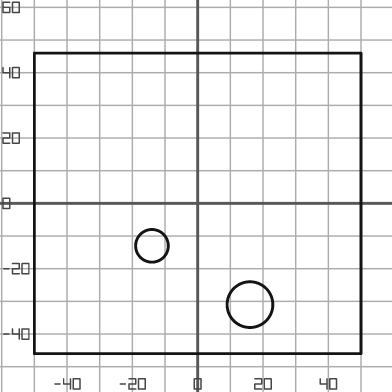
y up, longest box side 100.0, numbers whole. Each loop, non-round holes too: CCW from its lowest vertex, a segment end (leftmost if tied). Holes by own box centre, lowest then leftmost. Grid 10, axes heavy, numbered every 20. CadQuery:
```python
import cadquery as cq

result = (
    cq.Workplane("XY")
    .moveTo(-50.0, -46.0)
    .lineTo(50.0, -46.0)
    .lineTo(50.0, 46.0)
    .lineTo(-50.0, 46.0)
    .close()
    .moveTo(16.0, -31.0)
    .circle(7.0)
    .moveTo(-14.0, -13.0)
    .circle(5.0)
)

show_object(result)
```